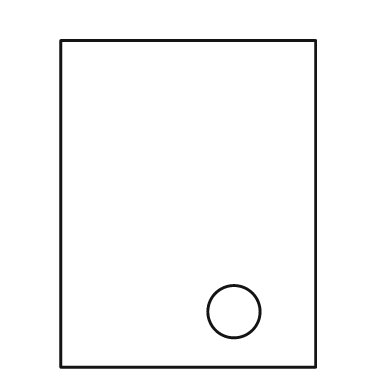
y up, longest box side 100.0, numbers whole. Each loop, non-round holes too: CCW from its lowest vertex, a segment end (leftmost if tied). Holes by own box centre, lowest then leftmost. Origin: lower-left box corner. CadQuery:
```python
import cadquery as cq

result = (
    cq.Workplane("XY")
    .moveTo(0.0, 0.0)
    .lineTo(78.0, 0.0)
    .lineTo(78.0, 100.0)
    .lineTo(0.0, 100.0)
    .close()
    .moveTo(53.0, 17.0)
    .circle(8.0)
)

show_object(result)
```